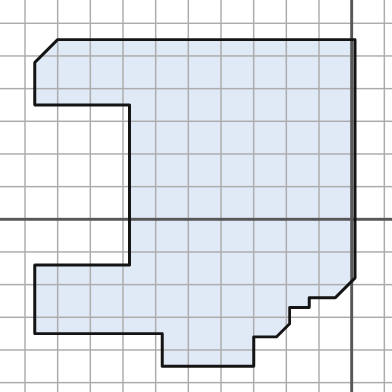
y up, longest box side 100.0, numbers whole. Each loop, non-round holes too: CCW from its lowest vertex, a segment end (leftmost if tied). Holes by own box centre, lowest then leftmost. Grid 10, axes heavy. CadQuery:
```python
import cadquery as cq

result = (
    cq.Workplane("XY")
    .moveTo(-58.0, -45.0)
    .lineTo(-30.0, -45.0)
    .lineTo(-30.0, -36.0)
    .lineTo(-23.0, -36.0)
    .lineTo(-19.0, -32.0)
    .lineTo(-19.0, -27.0)
    .lineTo(-13.0, -27.0)
    .lineTo(-13.0, -24.0)
    .lineTo(-5.0, -24.0)
    .lineTo(1.0, -18.0)
    .lineTo(1.0, 55.0)
    .lineTo(-90.0, 55.0)
    .lineTo(-97.0, 48.0)
    .lineTo(-97.0, 35.0)
    .lineTo(-68.0, 35.0)
    .lineTo(-68.0, -14.0)
    .lineTo(-97.0, -14.0)
    .lineTo(-97.0, -35.0)
    .lineTo(-58.0, -35.0)
    .close()
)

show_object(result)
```